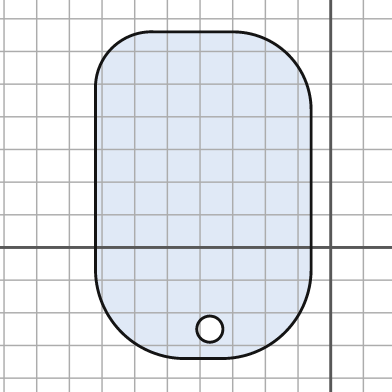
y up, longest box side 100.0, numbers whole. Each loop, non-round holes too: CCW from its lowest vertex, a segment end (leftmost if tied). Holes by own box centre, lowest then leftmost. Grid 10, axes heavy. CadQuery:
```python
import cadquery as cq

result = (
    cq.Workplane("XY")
    .moveTo(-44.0, -34.0)
    .lineTo(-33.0, -34.0)
    .threePointArc((-14.0, -26.0), (-6.0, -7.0))
    .lineTo(-6.0, 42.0)
    .threePointArc((-13.0, 59.0), (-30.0, 66.0))
    .lineTo(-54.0, 66.0)
    .threePointArc((-67.0, 61.0), (-72.0, 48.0))
    .lineTo(-72.0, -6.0)
    .threePointArc((-64.0, -26.0), (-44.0, -34.0))
    .close()
    .moveTo(-37.0, -25.0)
    .circle(4.0)
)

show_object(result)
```